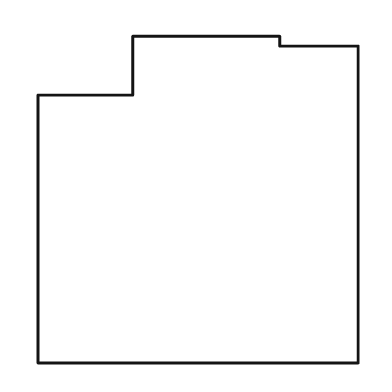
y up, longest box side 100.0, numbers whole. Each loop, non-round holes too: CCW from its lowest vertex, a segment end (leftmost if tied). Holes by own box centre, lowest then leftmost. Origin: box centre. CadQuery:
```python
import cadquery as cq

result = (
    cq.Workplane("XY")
    .moveTo(-49.0, -50.0)
    .lineTo(49.0, -50.0)
    .lineTo(49.0, 47.0)
    .lineTo(25.0, 47.0)
    .lineTo(25.0, 50.0)
    .lineTo(-20.0, 50.0)
    .lineTo(-20.0, 32.0)
    .lineTo(-49.0, 32.0)
    .close()
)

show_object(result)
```